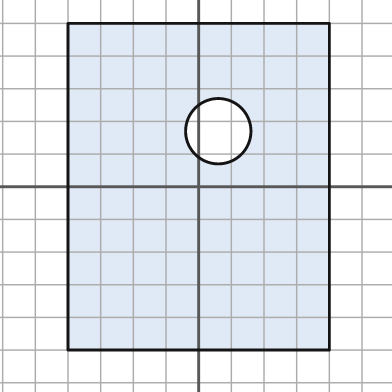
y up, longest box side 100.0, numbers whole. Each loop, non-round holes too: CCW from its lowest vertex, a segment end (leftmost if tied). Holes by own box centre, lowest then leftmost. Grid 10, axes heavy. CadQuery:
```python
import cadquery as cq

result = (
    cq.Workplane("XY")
    .moveTo(-40.0, -50.0)
    .lineTo(40.0, -50.0)
    .lineTo(40.0, 50.0)
    .lineTo(-40.0, 50.0)
    .close()
    .moveTo(6.0, 17.0)
    .circle(10.0)
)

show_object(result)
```